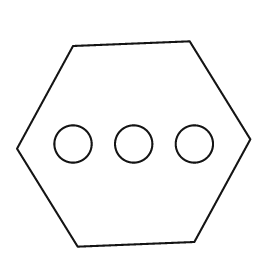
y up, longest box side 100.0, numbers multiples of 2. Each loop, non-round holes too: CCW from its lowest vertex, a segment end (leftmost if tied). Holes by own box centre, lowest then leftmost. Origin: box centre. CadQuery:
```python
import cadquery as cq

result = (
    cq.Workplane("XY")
    .moveTo(-24.0, -44.0)
    .lineTo(26.0, -42.0)
    .lineTo(50.0, 2.0)
    .lineTo(24.0, 44.0)
    .lineTo(-26.0, 42.0)
    .lineTo(-50.0, -2.0)
    .close()
    .moveTo(-26.0, 0.0)
    .circle(8.0)
    .moveTo(0.0, 0.0)
    .circle(8.0)
    .moveTo(26.0, 0.0)
    .circle(8.0)
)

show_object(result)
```